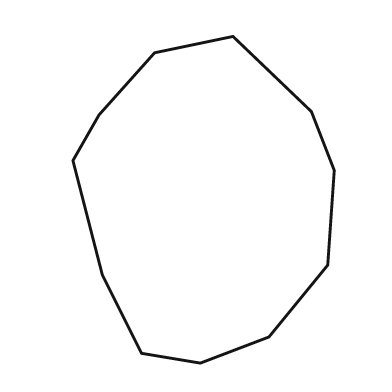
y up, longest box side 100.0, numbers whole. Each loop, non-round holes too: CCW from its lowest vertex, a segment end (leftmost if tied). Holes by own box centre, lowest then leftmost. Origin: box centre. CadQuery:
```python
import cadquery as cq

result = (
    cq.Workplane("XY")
    .moveTo(-1.0, -50.0)
    .lineTo(20.0, -42.0)
    .lineTo(38.0, -20.0)
    .lineTo(40.0, 9.0)
    .lineTo(33.0, 27.0)
    .lineTo(9.0, 50.0)
    .lineTo(-15.0, 45.0)
    .lineTo(-32.0, 26.0)
    .lineTo(-40.0, 12.0)
    .lineTo(-31.0, -23.0)
    .lineTo(-19.0, -47.0)
    .close()
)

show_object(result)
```